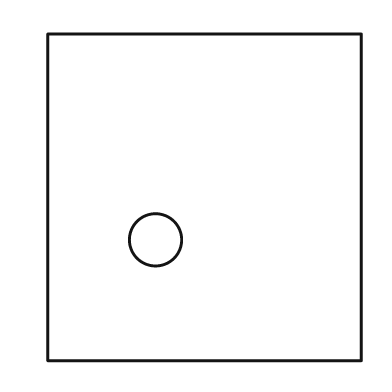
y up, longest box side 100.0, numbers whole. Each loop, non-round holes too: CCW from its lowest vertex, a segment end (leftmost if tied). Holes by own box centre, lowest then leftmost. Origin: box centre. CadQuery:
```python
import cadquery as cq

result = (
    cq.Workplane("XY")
    .moveTo(-48.0, -50.0)
    .lineTo(48.0, -50.0)
    .lineTo(48.0, 50.0)
    .lineTo(-48.0, 50.0)
    .close()
    .moveTo(-15.0, -13.0)
    .circle(8.0)
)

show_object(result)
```